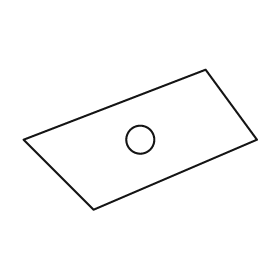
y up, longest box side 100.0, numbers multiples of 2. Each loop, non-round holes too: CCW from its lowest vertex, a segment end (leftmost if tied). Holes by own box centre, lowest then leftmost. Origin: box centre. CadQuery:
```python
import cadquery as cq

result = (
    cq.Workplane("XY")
    .moveTo(-20.0, -30.0)
    .lineTo(50.0, 0.0)
    .lineTo(28.0, 30.0)
    .lineTo(-50.0, 0.0)
    .close()
    .moveTo(0.0, 0.0)
    .circle(6.0)
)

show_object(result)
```